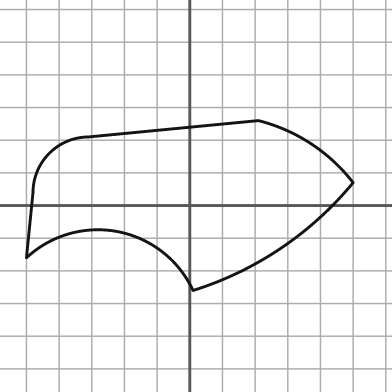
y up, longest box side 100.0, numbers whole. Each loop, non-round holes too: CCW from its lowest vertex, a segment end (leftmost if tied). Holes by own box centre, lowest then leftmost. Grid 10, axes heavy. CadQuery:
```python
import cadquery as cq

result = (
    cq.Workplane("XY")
    .moveTo(1.0, -26.0)
    .threePointArc((28.0, -13.0), (50.0, 7.0))
    .threePointArc((37.0, 19.0), (21.0, 26.0))
    .lineTo(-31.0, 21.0)
    .threePointArc((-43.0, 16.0), (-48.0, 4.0))
    .lineTo(-50.0, -16.0)
    .threePointArc((-22.0, -8.0), (1.0, -26.0))
    .close()
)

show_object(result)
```